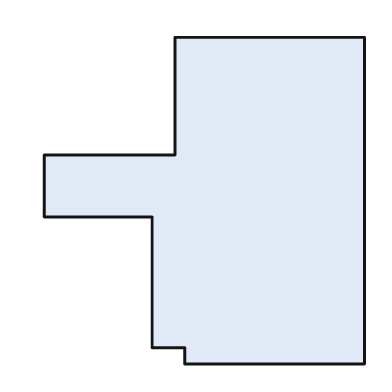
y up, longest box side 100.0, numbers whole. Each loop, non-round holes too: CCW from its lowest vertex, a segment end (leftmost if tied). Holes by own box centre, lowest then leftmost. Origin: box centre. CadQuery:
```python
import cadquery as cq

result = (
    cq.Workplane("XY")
    .moveTo(-6.0, -50.0)
    .lineTo(49.0, -50.0)
    .lineTo(49.0, 50.0)
    .lineTo(-9.0, 50.0)
    .lineTo(-9.0, 14.0)
    .lineTo(-49.0, 14.0)
    .lineTo(-49.0, -5.0)
    .lineTo(-16.0, -5.0)
    .lineTo(-16.0, -45.0)
    .lineTo(-6.0, -45.0)
    .close()
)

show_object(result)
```